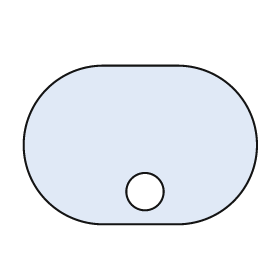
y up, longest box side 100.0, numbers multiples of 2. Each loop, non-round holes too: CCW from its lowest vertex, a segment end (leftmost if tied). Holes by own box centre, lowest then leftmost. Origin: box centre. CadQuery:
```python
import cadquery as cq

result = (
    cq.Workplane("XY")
    .moveTo(-16.0, -34.0)
    .lineTo(16.0, -34.0)
    .threePointArc((50.0, 0.0), (16.0, 34.0))
    .lineTo(-16.0, 34.0)
    .threePointArc((-50.0, 0.0), (-16.0, -34.0))
    .close()
    .moveTo(2.0, -20.0)
    .circle(8.0)
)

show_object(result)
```